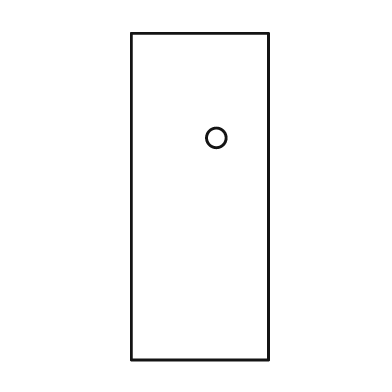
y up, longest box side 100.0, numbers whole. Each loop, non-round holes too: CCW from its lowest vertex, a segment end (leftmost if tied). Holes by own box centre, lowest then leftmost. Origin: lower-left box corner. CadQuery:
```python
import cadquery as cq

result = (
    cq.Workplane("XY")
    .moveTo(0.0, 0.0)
    .lineTo(42.0, 0.0)
    .lineTo(42.0, 100.0)
    .lineTo(0.0, 100.0)
    .close()
    .moveTo(26.0, 68.0)
    .circle(3.0)
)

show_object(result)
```